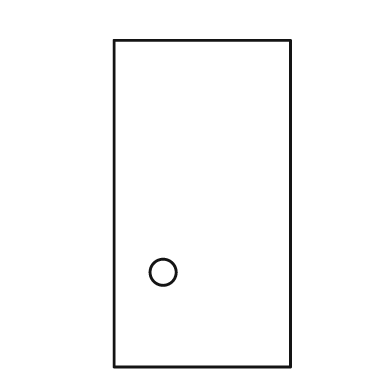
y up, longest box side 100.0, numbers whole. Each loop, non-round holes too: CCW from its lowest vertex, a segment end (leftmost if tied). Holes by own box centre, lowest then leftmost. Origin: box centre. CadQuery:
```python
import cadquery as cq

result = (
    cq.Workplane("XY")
    .moveTo(-27.0, -50.0)
    .lineTo(27.0, -50.0)
    .lineTo(27.0, 50.0)
    .lineTo(-27.0, 50.0)
    .close()
    .moveTo(-12.0, -21.0)
    .circle(4.0)
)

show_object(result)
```